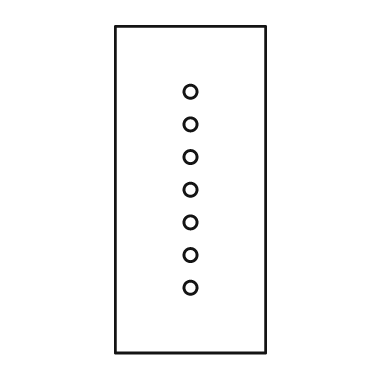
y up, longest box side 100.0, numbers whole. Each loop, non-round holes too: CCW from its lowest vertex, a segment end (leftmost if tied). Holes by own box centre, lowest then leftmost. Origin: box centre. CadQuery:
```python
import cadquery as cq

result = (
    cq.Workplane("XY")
    .moveTo(-23.0, -50.0)
    .lineTo(23.0, -50.0)
    .lineTo(23.0, 50.0)
    .lineTo(-23.0, 50.0)
    .close()
    .moveTo(0.0, -30.0)
    .circle(2.0)
    .moveTo(0.0, -20.0)
    .circle(2.0)
    .moveTo(0.0, -10.0)
    .circle(2.0)
    .moveTo(0.0, 0.0)
    .circle(2.0)
    .moveTo(0.0, 10.0)
    .circle(2.0)
    .moveTo(0.0, 20.0)
    .circle(2.0)
    .moveTo(0.0, 30.0)
    .circle(2.0)
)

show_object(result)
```